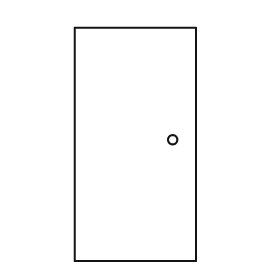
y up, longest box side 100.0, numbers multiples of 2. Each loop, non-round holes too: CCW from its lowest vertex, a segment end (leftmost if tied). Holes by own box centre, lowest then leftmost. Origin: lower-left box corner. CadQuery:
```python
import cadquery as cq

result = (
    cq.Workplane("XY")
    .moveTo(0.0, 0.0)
    .lineTo(52.0, 0.0)
    .lineTo(52.0, 100.0)
    .lineTo(0.0, 100.0)
    .close()
    .moveTo(42.0, 52.0)
    .circle(2.0)
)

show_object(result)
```